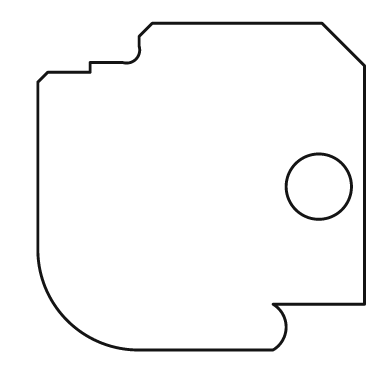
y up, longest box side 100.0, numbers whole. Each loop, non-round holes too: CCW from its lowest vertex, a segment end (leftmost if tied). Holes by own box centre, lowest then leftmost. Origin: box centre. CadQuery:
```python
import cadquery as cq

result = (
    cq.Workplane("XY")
    .moveTo(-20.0, -50.0)
    .lineTo(22.0, -50.0)
    .threePointArc((26.0, -43.0), (22.0, -36.0))
    .lineTo(50.0, -36.0)
    .lineTo(50.0, 37.0)
    .lineTo(37.0, 50.0)
    .lineTo(-15.0, 50.0)
    .lineTo(-19.0, 46.0)
    .lineTo(-19.0, 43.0)
    .threePointArc((-20.0, 39.0), (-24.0, 38.0))
    .lineTo(-34.0, 38.0)
    .lineTo(-34.0, 35.0)
    .lineTo(-47.0, 35.0)
    .lineTo(-50.0, 32.0)
    .lineTo(-50.0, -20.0)
    .threePointArc((-41.0, -41.0), (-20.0, -50.0))
    .close()
    .moveTo(36.0, 0.0)
    .circle(10.0)
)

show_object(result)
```